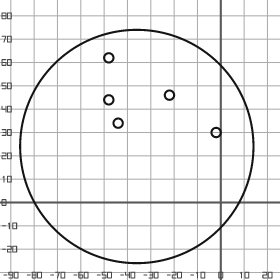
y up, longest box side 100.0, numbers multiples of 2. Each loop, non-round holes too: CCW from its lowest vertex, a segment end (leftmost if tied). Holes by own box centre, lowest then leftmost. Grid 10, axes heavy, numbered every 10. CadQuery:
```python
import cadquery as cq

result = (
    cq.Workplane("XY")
    .moveTo(-36.0, 24.0)
    .circle(50.0)
    .moveTo(-2.0, 30.0)
    .circle(2.0)
    .moveTo(-44.0, 34.0)
    .circle(2.0)
    .moveTo(-48.0, 44.0)
    .circle(2.0)
    .moveTo(-22.0, 46.0)
    .circle(2.0)
    .moveTo(-48.0, 62.0)
    .circle(2.0)
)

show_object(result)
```